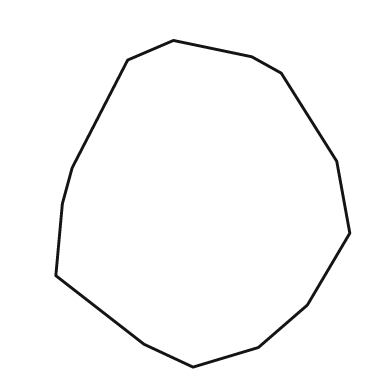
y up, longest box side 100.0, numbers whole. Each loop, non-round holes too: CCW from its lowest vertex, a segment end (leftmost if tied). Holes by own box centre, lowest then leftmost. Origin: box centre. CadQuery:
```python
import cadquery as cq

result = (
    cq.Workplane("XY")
    .moveTo(-3.0, -50.0)
    .lineTo(17.0, -44.0)
    .lineTo(32.0, -31.0)
    .lineTo(45.0, -9.0)
    .lineTo(41.0, 13.0)
    .lineTo(24.0, 40.0)
    .lineTo(15.0, 45.0)
    .lineTo(-9.0, 50.0)
    .lineTo(-23.0, 44.0)
    .lineTo(-40.0, 11.0)
    .lineTo(-43.0, 0.0)
    .lineTo(-45.0, -22.0)
    .lineTo(-18.0, -43.0)
    .close()
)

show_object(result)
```